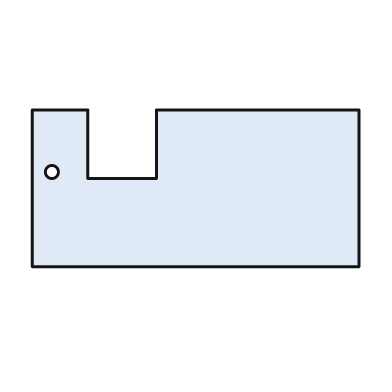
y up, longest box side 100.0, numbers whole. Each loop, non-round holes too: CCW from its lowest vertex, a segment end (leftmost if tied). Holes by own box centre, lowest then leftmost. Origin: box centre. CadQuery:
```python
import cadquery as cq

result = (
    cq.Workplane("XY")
    .moveTo(-50.0, -24.0)
    .lineTo(50.0, -24.0)
    .lineTo(50.0, 24.0)
    .lineTo(-12.0, 24.0)
    .lineTo(-12.0, 3.0)
    .lineTo(-33.0, 3.0)
    .lineTo(-33.0, 24.0)
    .lineTo(-50.0, 24.0)
    .close()
    .moveTo(-44.0, 5.0)
    .circle(2.0)
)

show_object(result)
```